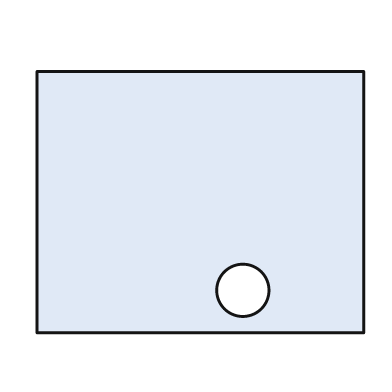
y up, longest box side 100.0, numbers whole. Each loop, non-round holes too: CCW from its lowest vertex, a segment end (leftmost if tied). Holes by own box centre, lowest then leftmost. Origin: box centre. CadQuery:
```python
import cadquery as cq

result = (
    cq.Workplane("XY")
    .moveTo(-50.0, -40.0)
    .lineTo(50.0, -40.0)
    .lineTo(50.0, 40.0)
    .lineTo(-50.0, 40.0)
    .close()
    .moveTo(13.0, -27.0)
    .circle(8.0)
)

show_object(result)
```